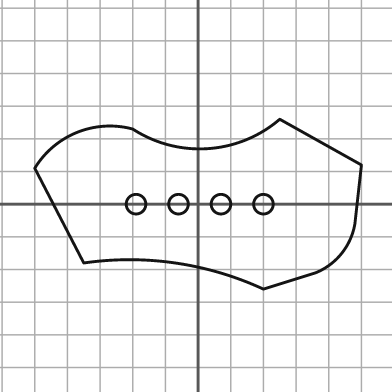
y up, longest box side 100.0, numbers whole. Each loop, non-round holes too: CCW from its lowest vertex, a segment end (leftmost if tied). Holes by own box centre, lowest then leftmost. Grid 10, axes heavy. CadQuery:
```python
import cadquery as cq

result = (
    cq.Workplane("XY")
    .moveTo(20.0, -26.0)
    .lineTo(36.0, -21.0)
    .threePointArc((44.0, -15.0), (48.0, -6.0))
    .lineTo(50.0, 12.0)
    .lineTo(25.0, 26.0)
    .threePointArc((3.0, 17.0), (-20.0, 23.0))
    .threePointArc((-37.0, 22.0), (-50.0, 11.0))
    .lineTo(-35.0, -18.0)
    .threePointArc((-7.0, -18.0), (20.0, -26.0))
    .close()
    .moveTo(-19.0, 0.0)
    .circle(3.0)
    .moveTo(-6.0, 0.0)
    .circle(3.0)
    .moveTo(7.0, 0.0)
    .circle(3.0)
    .moveTo(20.0, 0.0)
    .circle(3.0)
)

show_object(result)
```